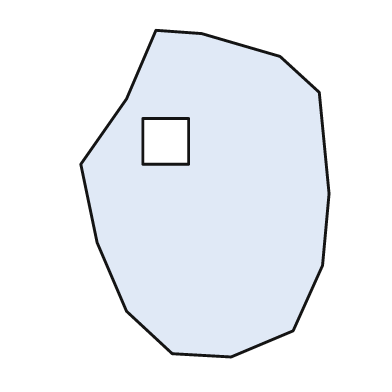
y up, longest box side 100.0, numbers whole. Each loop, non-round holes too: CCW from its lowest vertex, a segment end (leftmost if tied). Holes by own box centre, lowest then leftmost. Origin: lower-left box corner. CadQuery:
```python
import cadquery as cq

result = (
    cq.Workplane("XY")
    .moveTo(46.0, 0.0)
    .lineTo(65.0, 8.0)
    .lineTo(74.0, 28.0)
    .lineTo(76.0, 50.0)
    .lineTo(73.0, 81.0)
    .lineTo(61.0, 92.0)
    .lineTo(37.0, 99.0)
    .lineTo(23.0, 100.0)
    .lineTo(14.0, 79.0)
    .lineTo(0.0, 59.0)
    .lineTo(5.0, 35.0)
    .lineTo(14.0, 14.0)
    .lineTo(28.0, 1.0)
    .close()
    .moveTo(19.0, 59.0)
    .lineTo(33.0, 59.0)
    .lineTo(33.0, 73.0)
    .lineTo(19.0, 73.0)
    .close()
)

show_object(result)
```